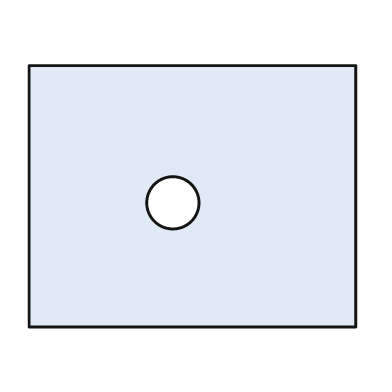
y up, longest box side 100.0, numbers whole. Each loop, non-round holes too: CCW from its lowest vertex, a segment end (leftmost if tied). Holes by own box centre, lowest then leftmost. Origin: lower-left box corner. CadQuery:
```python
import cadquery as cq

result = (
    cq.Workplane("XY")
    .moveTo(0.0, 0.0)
    .lineTo(100.0, 0.0)
    .lineTo(100.0, 80.0)
    .lineTo(0.0, 80.0)
    .close()
    .moveTo(44.0, 38.0)
    .circle(8.0)
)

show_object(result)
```